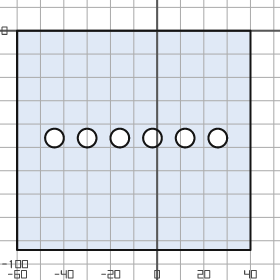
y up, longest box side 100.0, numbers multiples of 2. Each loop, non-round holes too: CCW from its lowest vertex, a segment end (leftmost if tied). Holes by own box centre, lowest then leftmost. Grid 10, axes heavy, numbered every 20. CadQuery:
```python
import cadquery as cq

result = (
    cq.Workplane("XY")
    .moveTo(-60.0, -94.0)
    .lineTo(40.0, -94.0)
    .lineTo(40.0, 0.0)
    .lineTo(-60.0, 0.0)
    .close()
    .moveTo(-44.0, -46.0)
    .circle(4.0)
    .moveTo(-30.0, -46.0)
    .circle(4.0)
    .moveTo(-16.0, -46.0)
    .circle(4.0)
    .moveTo(-2.0, -46.0)
    .circle(4.0)
    .moveTo(12.0, -46.0)
    .circle(4.0)
    .moveTo(26.0, -46.0)
    .circle(4.0)
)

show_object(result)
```